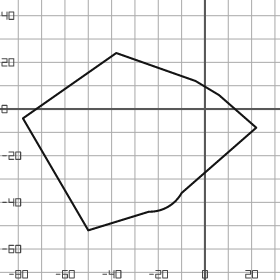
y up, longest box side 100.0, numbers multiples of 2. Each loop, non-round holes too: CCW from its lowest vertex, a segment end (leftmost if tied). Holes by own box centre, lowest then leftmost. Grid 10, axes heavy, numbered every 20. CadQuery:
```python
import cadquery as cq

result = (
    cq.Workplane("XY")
    .moveTo(-50.0, -52.0)
    .lineTo(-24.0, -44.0)
    .threePointArc((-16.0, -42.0), (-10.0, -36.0))
    .lineTo(22.0, -8.0)
    .lineTo(6.0, 6.0)
    .lineTo(-4.0, 12.0)
    .lineTo(-38.0, 24.0)
    .lineTo(-78.0, -4.0)
    .close()
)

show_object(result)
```